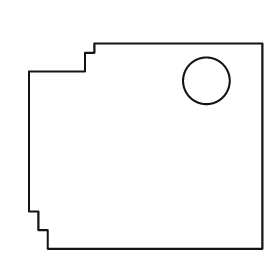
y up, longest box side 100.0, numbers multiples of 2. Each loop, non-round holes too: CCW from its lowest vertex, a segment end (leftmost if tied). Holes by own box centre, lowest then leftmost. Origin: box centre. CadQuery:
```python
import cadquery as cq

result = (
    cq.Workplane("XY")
    .moveTo(-42.0, -44.0)
    .lineTo(50.0, -44.0)
    .lineTo(50.0, 44.0)
    .lineTo(-22.0, 44.0)
    .lineTo(-22.0, 40.0)
    .lineTo(-26.0, 40.0)
    .lineTo(-26.0, 32.0)
    .lineTo(-50.0, 32.0)
    .lineTo(-50.0, -28.0)
    .lineTo(-46.0, -28.0)
    .lineTo(-46.0, -36.0)
    .lineTo(-42.0, -36.0)
    .close()
    .moveTo(26.0, 28.0)
    .circle(10.0)
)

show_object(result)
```